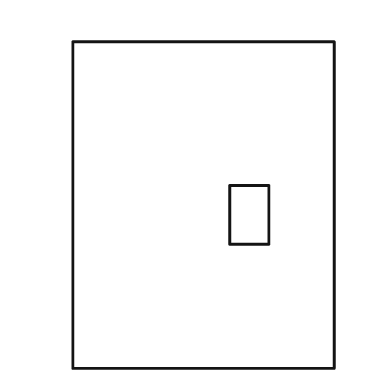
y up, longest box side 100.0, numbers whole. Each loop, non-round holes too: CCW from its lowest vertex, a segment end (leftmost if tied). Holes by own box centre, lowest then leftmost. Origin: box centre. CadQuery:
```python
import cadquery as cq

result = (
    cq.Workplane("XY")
    .moveTo(-40.0, -50.0)
    .lineTo(40.0, -50.0)
    .lineTo(40.0, 50.0)
    .lineTo(-40.0, 50.0)
    .close()
    .moveTo(8.0, -12.0)
    .lineTo(20.0, -12.0)
    .lineTo(20.0, 6.0)
    .lineTo(8.0, 6.0)
    .close()
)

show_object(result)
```